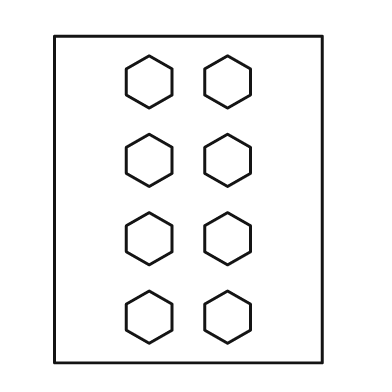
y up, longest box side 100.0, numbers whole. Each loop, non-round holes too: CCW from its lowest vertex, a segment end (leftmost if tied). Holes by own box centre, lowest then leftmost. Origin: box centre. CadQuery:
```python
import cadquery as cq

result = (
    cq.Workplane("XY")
    .moveTo(-41.0, -50.0)
    .lineTo(41.0, -50.0)
    .lineTo(41.0, 50.0)
    .lineTo(-41.0, 50.0)
    .close()
    .moveTo(-12.0, -44.0)
    .lineTo(-5.0, -40.0)
    .lineTo(-5.0, -32.0)
    .lineTo(-12.0, -28.0)
    .lineTo(-19.0, -32.0)
    .lineTo(-19.0, -40.0)
    .close()
    .moveTo(12.0, -44.0)
    .lineTo(19.0, -40.0)
    .lineTo(19.0, -32.0)
    .lineTo(12.0, -28.0)
    .lineTo(5.0, -32.0)
    .lineTo(5.0, -40.0)
    .close()
    .moveTo(-12.0, -20.0)
    .lineTo(-5.0, -16.0)
    .lineTo(-5.0, -8.0)
    .lineTo(-12.0, -4.0)
    .lineTo(-19.0, -8.0)
    .lineTo(-19.0, -16.0)
    .close()
    .moveTo(12.0, -20.0)
    .lineTo(19.0, -16.0)
    .lineTo(19.0, -8.0)
    .lineTo(12.0, -4.0)
    .lineTo(5.0, -8.0)
    .lineTo(5.0, -16.0)
    .close()
    .moveTo(-12.0, 4.0)
    .lineTo(-5.0, 8.0)
    .lineTo(-5.0, 16.0)
    .lineTo(-12.0, 20.0)
    .lineTo(-19.0, 16.0)
    .lineTo(-19.0, 8.0)
    .close()
    .moveTo(12.0, 4.0)
    .lineTo(19.0, 8.0)
    .lineTo(19.0, 16.0)
    .lineTo(12.0, 20.0)
    .lineTo(5.0, 16.0)
    .lineTo(5.0, 8.0)
    .close()
    .moveTo(-12.0, 28.0)
    .lineTo(-5.0, 32.0)
    .lineTo(-5.0, 40.0)
    .lineTo(-12.0, 44.0)
    .lineTo(-19.0, 40.0)
    .lineTo(-19.0, 32.0)
    .close()
    .moveTo(12.0, 28.0)
    .lineTo(19.0, 32.0)
    .lineTo(19.0, 40.0)
    .lineTo(12.0, 44.0)
    .lineTo(5.0, 40.0)
    .lineTo(5.0, 32.0)
    .close()
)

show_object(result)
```